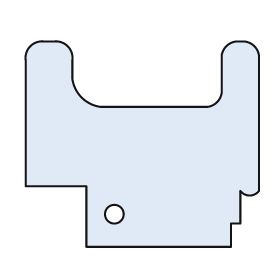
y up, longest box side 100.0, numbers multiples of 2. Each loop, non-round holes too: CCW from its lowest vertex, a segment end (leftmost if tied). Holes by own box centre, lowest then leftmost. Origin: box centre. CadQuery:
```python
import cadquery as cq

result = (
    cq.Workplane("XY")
    .moveTo(-24.0, -44.0)
    .lineTo(38.0, -44.0)
    .lineTo(38.0, -34.0)
    .lineTo(42.0, -34.0)
    .lineTo(42.0, -20.0)
    .threePointArc((46.0, -22.0), (50.0, -20.0))
    .lineTo(50.0, 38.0)
    .threePointArc((48.0, 42.0), (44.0, 44.0))
    .lineTo(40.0, 44.0)
    .threePointArc((36.0, 42.0), (34.0, 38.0))
    .lineTo(34.0, 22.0)
    .threePointArc((32.0, 18.0), (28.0, 16.0))
    .lineTo(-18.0, 16.0)
    .threePointArc((-26.0, 20.0), (-30.0, 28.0))
    .lineTo(-30.0, 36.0)
    .threePointArc((-32.0, 42.0), (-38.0, 44.0))
    .lineTo(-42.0, 44.0)
    .threePointArc((-48.0, 42.0), (-50.0, 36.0))
    .lineTo(-50.0, -18.0)
    .lineTo(-24.0, -18.0)
    .close()
    .moveTo(-12.0, -30.0)
    .circle(4.0)
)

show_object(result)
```